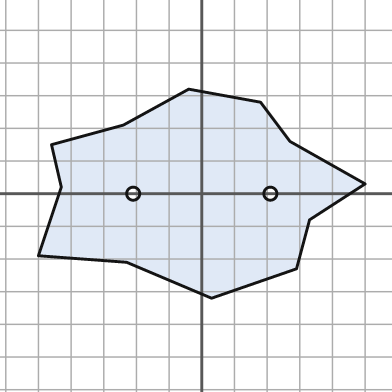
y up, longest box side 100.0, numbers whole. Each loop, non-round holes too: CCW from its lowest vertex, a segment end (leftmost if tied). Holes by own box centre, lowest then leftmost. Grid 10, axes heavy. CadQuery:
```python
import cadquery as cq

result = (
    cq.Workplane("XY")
    .moveTo(3.0, -32.0)
    .lineTo(29.0, -23.0)
    .lineTo(33.0, -8.0)
    .lineTo(50.0, 3.0)
    .lineTo(27.0, 16.0)
    .lineTo(18.0, 28.0)
    .lineTo(-4.0, 32.0)
    .lineTo(-24.0, 21.0)
    .lineTo(-46.0, 15.0)
    .lineTo(-43.0, 2.0)
    .lineTo(-50.0, -19.0)
    .lineTo(-23.0, -21.0)
    .close()
    .moveTo(-21.0, 0.0)
    .circle(2.0)
    .moveTo(21.0, 0.0)
    .circle(2.0)
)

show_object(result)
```